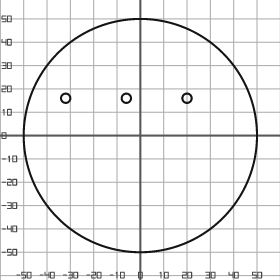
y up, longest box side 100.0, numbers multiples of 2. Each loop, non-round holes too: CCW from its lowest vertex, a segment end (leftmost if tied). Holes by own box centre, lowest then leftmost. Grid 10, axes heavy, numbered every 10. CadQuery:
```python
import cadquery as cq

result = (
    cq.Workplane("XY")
    .moveTo(0.0, 0.0)
    .circle(50.0)
    .moveTo(-32.0, 16.0)
    .circle(2.0)
    .moveTo(-6.0, 16.0)
    .circle(2.0)
    .moveTo(20.0, 16.0)
    .circle(2.0)
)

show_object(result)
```